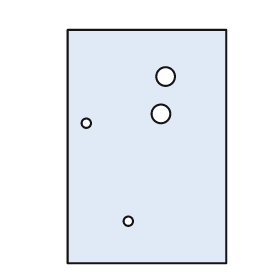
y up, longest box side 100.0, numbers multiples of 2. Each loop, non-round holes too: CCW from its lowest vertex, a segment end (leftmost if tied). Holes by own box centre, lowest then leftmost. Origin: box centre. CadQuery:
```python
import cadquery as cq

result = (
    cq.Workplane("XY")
    .moveTo(-34.0, -50.0)
    .lineTo(34.0, -50.0)
    .lineTo(34.0, 50.0)
    .lineTo(-34.0, 50.0)
    .close()
    .moveTo(-8.0, -32.0)
    .circle(2.0)
    .moveTo(-26.0, 10.0)
    .circle(2.0)
    .moveTo(6.0, 14.0)
    .circle(4.0)
    .moveTo(8.0, 30.0)
    .circle(4.0)
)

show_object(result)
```